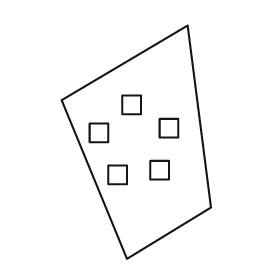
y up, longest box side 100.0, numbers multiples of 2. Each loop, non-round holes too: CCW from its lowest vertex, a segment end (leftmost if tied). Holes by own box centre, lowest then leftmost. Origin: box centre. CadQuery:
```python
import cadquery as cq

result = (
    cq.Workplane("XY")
    .moveTo(-4.0, -50.0)
    .lineTo(32.0, -28.0)
    .lineTo(22.0, 50.0)
    .lineTo(-32.0, 18.0)
    .close()
    .moveTo(-12.0, -18.0)
    .lineTo(-4.0, -18.0)
    .lineTo(-4.0, -10.0)
    .lineTo(-12.0, -10.0)
    .close()
    .moveTo(6.0, -16.0)
    .lineTo(14.0, -16.0)
    .lineTo(14.0, -8.0)
    .lineTo(6.0, -8.0)
    .close()
    .moveTo(-20.0, 0.0)
    .lineTo(-12.0, 0.0)
    .lineTo(-12.0, 8.0)
    .lineTo(-20.0, 8.0)
    .close()
    .moveTo(10.0, 2.0)
    .lineTo(18.0, 2.0)
    .lineTo(18.0, 10.0)
    .lineTo(10.0, 10.0)
    .close()
    .moveTo(-6.0, 12.0)
    .lineTo(2.0, 12.0)
    .lineTo(2.0, 20.0)
    .lineTo(-6.0, 20.0)
    .close()
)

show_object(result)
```